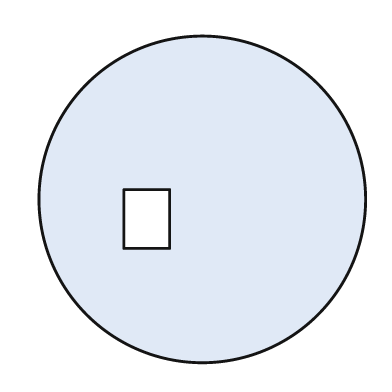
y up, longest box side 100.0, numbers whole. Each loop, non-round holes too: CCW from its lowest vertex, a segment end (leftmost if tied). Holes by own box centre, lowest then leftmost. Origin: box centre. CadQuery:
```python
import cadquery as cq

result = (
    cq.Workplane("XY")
    .moveTo(0.0, 0.0)
    .circle(50.0)
    .moveTo(-24.0, -15.0)
    .lineTo(-10.0, -15.0)
    .lineTo(-10.0, 3.0)
    .lineTo(-24.0, 3.0)
    .close()
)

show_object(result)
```